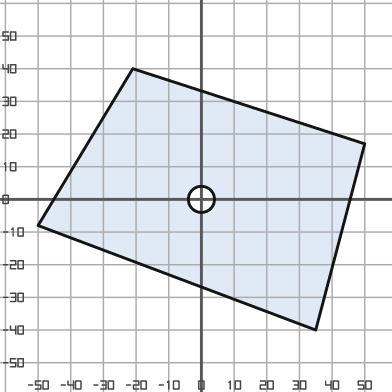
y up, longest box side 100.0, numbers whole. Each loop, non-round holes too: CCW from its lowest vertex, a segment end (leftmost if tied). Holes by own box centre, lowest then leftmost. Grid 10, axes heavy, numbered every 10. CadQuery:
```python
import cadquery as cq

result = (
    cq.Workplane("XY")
    .moveTo(35.0, -40.0)
    .lineTo(50.0, 17.0)
    .lineTo(-21.0, 40.0)
    .lineTo(-50.0, -8.0)
    .close()
    .moveTo(0.0, 0.0)
    .circle(4.0)
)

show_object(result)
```